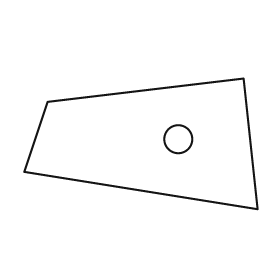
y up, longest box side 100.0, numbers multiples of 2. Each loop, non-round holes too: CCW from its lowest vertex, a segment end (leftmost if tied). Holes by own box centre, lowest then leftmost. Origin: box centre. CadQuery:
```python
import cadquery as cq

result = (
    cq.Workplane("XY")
    .moveTo(50.0, -28.0)
    .lineTo(44.0, 28.0)
    .lineTo(-40.0, 18.0)
    .lineTo(-50.0, -12.0)
    .close()
    .moveTo(16.0, 2.0)
    .circle(6.0)
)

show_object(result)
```